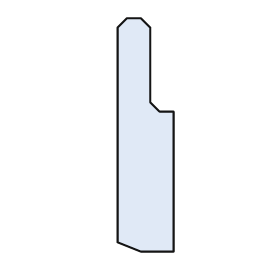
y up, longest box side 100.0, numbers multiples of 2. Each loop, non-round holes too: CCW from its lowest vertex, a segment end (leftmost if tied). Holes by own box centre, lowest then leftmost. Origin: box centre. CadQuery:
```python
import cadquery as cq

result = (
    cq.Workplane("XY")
    .moveTo(-2.0, -50.0)
    .lineTo(12.0, -50.0)
    .lineTo(12.0, 10.0)
    .lineTo(6.0, 10.0)
    .lineTo(2.0, 14.0)
    .lineTo(2.0, 46.0)
    .lineTo(-2.0, 50.0)
    .lineTo(-8.0, 50.0)
    .lineTo(-12.0, 46.0)
    .lineTo(-12.0, -46.0)
    .close()
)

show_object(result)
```